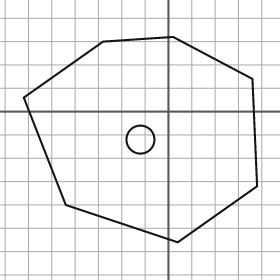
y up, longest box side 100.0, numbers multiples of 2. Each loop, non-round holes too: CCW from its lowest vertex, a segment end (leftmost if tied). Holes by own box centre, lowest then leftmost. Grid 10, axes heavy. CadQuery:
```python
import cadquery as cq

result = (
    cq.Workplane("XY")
    .moveTo(4.0, -56.0)
    .lineTo(38.0, -32.0)
    .lineTo(36.0, 14.0)
    .lineTo(2.0, 32.0)
    .lineTo(-28.0, 30.0)
    .lineTo(-62.0, 6.0)
    .lineTo(-44.0, -40.0)
    .close()
    .moveTo(-12.0, -12.0)
    .circle(6.0)
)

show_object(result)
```